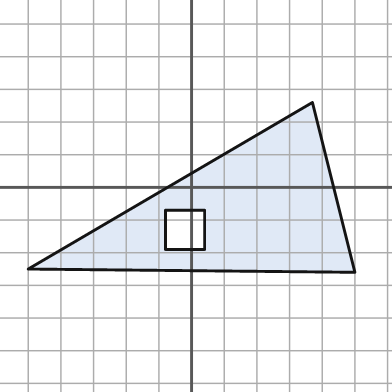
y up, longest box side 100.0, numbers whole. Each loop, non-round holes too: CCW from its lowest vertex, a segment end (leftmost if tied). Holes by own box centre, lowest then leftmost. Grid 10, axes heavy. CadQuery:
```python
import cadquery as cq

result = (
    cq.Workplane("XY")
    .moveTo(50.0, -26.0)
    .lineTo(37.0, 26.0)
    .lineTo(-50.0, -25.0)
    .close()
    .moveTo(-8.0, -19.0)
    .lineTo(4.0, -19.0)
    .lineTo(4.0, -7.0)
    .lineTo(-8.0, -7.0)
    .close()
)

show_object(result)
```